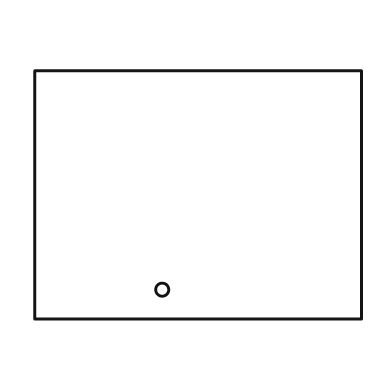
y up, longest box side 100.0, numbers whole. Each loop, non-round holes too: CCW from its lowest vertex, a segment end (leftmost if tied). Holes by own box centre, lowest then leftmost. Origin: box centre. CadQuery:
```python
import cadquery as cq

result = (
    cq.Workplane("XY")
    .moveTo(-50.0, -38.0)
    .lineTo(50.0, -38.0)
    .lineTo(50.0, 38.0)
    .lineTo(-50.0, 38.0)
    .close()
    .moveTo(-11.0, -29.0)
    .circle(2.0)
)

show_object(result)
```